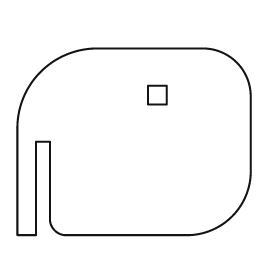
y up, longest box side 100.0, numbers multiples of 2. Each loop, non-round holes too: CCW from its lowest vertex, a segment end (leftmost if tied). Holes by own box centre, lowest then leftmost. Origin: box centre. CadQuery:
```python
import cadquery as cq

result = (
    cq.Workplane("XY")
    .moveTo(-50.0, -40.0)
    .lineTo(-42.0, -40.0)
    .lineTo(-42.0, 0.0)
    .lineTo(-36.0, 0.0)
    .lineTo(-36.0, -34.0)
    .threePointArc((-34.0, -38.0), (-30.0, -40.0))
    .lineTo(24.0, -40.0)
    .threePointArc((42.0, -32.0), (50.0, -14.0))
    .lineTo(50.0, 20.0)
    .threePointArc((44.0, 34.0), (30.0, 40.0))
    .lineTo(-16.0, 40.0)
    .threePointArc((-40.0, 30.0), (-50.0, 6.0))
    .close()
    .moveTo(6.0, 16.0)
    .lineTo(14.0, 16.0)
    .lineTo(14.0, 24.0)
    .lineTo(6.0, 24.0)
    .close()
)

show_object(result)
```